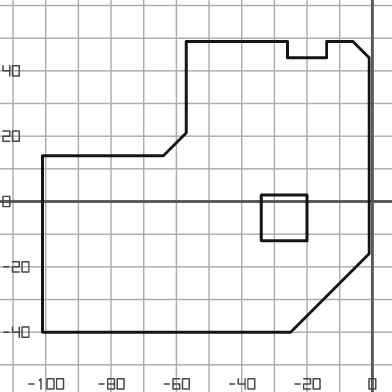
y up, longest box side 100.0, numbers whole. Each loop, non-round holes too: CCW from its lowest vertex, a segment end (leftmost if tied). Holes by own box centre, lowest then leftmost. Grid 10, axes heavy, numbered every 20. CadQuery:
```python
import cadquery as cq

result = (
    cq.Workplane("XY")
    .moveTo(-101.0, -40.0)
    .lineTo(-25.0, -40.0)
    .lineTo(-1.0, -16.0)
    .lineTo(-1.0, 44.0)
    .lineTo(-6.0, 49.0)
    .lineTo(-14.0, 49.0)
    .lineTo(-14.0, 44.0)
    .lineTo(-26.0, 44.0)
    .lineTo(-26.0, 49.0)
    .lineTo(-57.0, 49.0)
    .lineTo(-57.0, 21.0)
    .lineTo(-64.0, 14.0)
    .lineTo(-101.0, 14.0)
    .close()
    .moveTo(-34.0, -12.0)
    .lineTo(-20.0, -12.0)
    .lineTo(-20.0, 2.0)
    .lineTo(-34.0, 2.0)
    .close()
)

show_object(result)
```